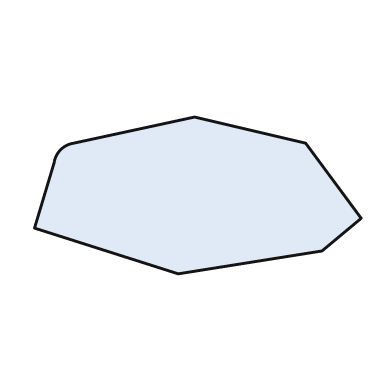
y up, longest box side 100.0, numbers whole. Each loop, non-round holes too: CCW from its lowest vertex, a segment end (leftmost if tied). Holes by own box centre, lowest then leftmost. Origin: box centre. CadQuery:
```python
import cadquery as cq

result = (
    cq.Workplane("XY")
    .moveTo(-6.0, -24.0)
    .lineTo(38.0, -17.0)
    .lineTo(50.0, -7.0)
    .lineTo(33.0, 16.0)
    .lineTo(-1.0, 24.0)
    .lineTo(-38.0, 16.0)
    .threePointArc((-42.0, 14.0), (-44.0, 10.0))
    .lineTo(-50.0, -10.0)
    .close()
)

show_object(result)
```